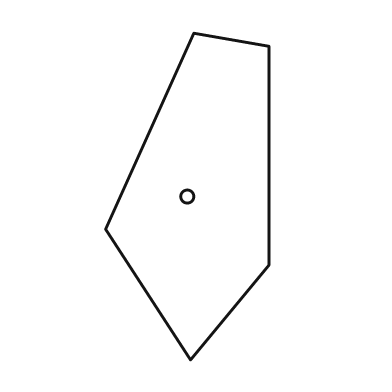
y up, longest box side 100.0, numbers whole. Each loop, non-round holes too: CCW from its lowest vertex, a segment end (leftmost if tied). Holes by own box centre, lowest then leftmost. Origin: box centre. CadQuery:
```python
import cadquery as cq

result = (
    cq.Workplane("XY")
    .moveTo(1.0, -50.0)
    .lineTo(25.0, -21.0)
    .lineTo(25.0, 46.0)
    .lineTo(2.0, 50.0)
    .lineTo(-25.0, -10.0)
    .close()
    .moveTo(0.0, 0.0)
    .circle(2.0)
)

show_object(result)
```